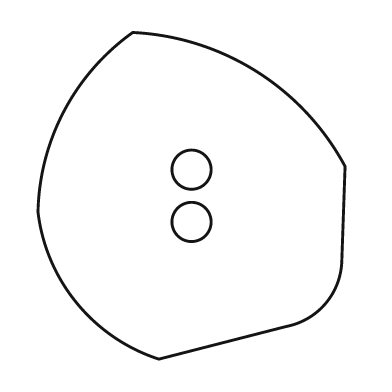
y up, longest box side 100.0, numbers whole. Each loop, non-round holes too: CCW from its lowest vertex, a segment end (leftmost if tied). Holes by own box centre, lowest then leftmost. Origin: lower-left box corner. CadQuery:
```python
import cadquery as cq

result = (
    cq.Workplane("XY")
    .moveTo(37.0, 0.0)
    .lineTo(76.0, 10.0)
    .threePointArc((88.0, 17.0), (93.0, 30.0))
    .lineTo(94.0, 59.0)
    .threePointArc((67.0, 88.0), (29.0, 100.0))
    .threePointArc((8.0, 76.0), (0.0, 45.0))
    .threePointArc((12.0, 17.0), (37.0, 0.0))
    .close()
    .moveTo(47.0, 42.0)
    .circle(6.0)
    .moveTo(47.0, 58.0)
    .circle(6.0)
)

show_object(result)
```